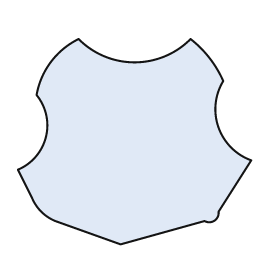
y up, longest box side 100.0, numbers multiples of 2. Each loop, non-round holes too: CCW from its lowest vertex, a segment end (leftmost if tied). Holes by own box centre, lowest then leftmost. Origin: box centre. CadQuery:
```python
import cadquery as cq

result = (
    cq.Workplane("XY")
    .moveTo(-6.0, -44.0)
    .lineTo(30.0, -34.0)
    .threePointArc((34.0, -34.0), (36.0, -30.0))
    .lineTo(50.0, -8.0)
    .threePointArc((36.0, 6.0), (38.0, 26.0))
    .threePointArc((32.0, 36.0), (24.0, 44.0))
    .threePointArc((0.0, 34.0), (-24.0, 44.0))
    .threePointArc((-36.0, 34.0), (-42.0, 20.0))
    .threePointArc((-38.0, 2.0), (-50.0, -12.0))
    .lineTo(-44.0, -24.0)
    .threePointArc((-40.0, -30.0), (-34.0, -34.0))
    .close()
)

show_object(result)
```